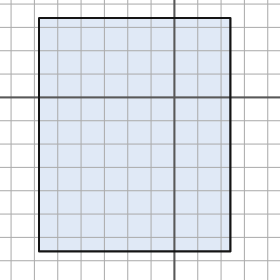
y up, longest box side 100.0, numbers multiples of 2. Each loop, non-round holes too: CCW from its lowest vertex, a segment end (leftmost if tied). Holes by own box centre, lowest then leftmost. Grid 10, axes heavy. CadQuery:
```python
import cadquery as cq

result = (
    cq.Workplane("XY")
    .moveTo(-58.0, -66.0)
    .lineTo(24.0, -66.0)
    .lineTo(24.0, 34.0)
    .lineTo(-58.0, 34.0)
    .close()
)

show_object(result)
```